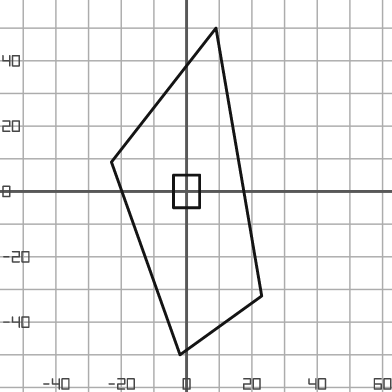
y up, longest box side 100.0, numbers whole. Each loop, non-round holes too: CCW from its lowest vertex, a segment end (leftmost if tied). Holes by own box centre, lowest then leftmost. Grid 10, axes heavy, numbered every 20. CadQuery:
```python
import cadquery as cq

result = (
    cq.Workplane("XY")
    .moveTo(-2.0, -50.0)
    .lineTo(23.0, -32.0)
    .lineTo(9.0, 50.0)
    .lineTo(-23.0, 9.0)
    .close()
    .moveTo(-4.0, -5.0)
    .lineTo(4.0, -5.0)
    .lineTo(4.0, 5.0)
    .lineTo(-4.0, 5.0)
    .close()
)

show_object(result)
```